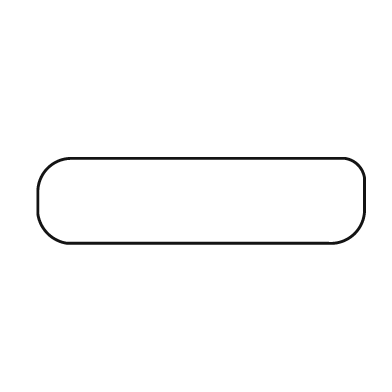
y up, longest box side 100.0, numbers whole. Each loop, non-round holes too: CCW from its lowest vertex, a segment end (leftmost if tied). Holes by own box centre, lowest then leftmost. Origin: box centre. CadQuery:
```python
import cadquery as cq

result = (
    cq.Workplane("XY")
    .moveTo(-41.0, -13.0)
    .lineTo(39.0, -13.0)
    .threePointArc((47.0, -10.0), (50.0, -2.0))
    .lineTo(50.0, 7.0)
    .threePointArc((48.0, 11.0), (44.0, 13.0))
    .lineTo(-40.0, 13.0)
    .threePointArc((-47.0, 10.0), (-50.0, 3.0))
    .lineTo(-50.0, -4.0)
    .threePointArc((-47.0, -10.0), (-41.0, -13.0))
    .close()
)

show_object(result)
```